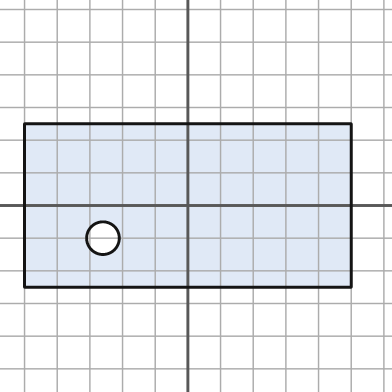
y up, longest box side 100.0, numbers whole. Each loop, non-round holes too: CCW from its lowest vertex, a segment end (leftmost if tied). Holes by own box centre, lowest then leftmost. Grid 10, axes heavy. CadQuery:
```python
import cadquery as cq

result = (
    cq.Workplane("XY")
    .moveTo(-50.0, -25.0)
    .lineTo(50.0, -25.0)
    .lineTo(50.0, 25.0)
    .lineTo(-50.0, 25.0)
    .close()
    .moveTo(-26.0, -10.0)
    .circle(5.0)
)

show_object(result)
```